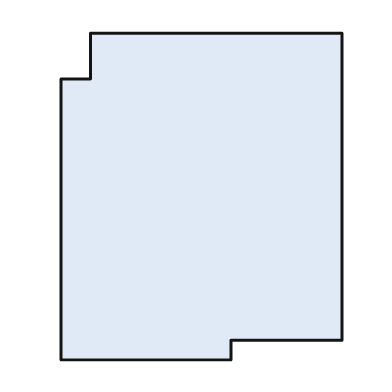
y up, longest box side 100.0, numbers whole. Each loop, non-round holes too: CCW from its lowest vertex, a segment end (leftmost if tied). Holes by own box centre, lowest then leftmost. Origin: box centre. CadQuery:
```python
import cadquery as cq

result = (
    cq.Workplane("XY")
    .moveTo(-43.0, -50.0)
    .lineTo(9.0, -50.0)
    .lineTo(9.0, -44.0)
    .lineTo(43.0, -44.0)
    .lineTo(43.0, 50.0)
    .lineTo(-34.0, 50.0)
    .lineTo(-34.0, 36.0)
    .lineTo(-43.0, 36.0)
    .close()
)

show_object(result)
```